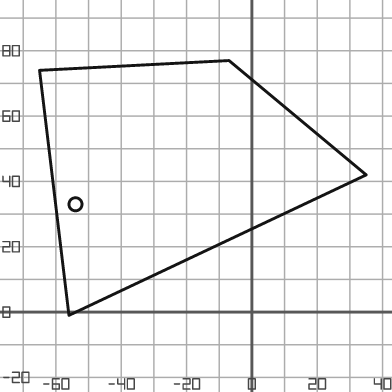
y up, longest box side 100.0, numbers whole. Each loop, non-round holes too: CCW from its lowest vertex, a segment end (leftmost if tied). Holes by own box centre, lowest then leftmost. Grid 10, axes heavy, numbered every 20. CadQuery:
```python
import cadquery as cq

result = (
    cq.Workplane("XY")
    .moveTo(-56.0, -1.0)
    .lineTo(35.0, 42.0)
    .lineTo(-7.0, 77.0)
    .lineTo(-65.0, 74.0)
    .close()
    .moveTo(-54.0, 33.0)
    .circle(2.0)
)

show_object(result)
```